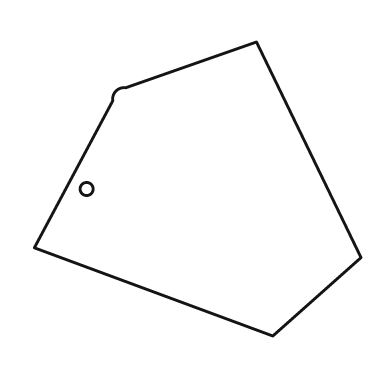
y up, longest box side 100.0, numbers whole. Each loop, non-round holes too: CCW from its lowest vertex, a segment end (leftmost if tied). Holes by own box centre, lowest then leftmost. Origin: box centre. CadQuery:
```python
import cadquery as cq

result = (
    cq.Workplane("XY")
    .moveTo(23.0, -45.0)
    .lineTo(50.0, -21.0)
    .lineTo(18.0, 45.0)
    .lineTo(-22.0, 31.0)
    .threePointArc((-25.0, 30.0), (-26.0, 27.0))
    .lineTo(-50.0, -18.0)
    .close()
    .moveTo(-34.0, 0.0)
    .circle(2.0)
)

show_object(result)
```